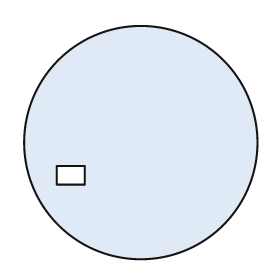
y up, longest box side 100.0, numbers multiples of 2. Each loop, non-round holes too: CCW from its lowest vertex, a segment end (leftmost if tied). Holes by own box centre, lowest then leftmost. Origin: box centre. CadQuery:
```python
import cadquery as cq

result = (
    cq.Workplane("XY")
    .moveTo(0.0, 0.0)
    .circle(50.0)
    .moveTo(-36.0, -18.0)
    .lineTo(-24.0, -18.0)
    .lineTo(-24.0, -10.0)
    .lineTo(-36.0, -10.0)
    .close()
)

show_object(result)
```